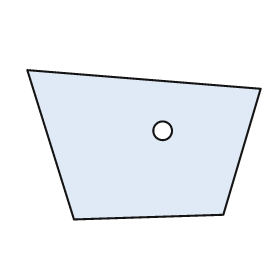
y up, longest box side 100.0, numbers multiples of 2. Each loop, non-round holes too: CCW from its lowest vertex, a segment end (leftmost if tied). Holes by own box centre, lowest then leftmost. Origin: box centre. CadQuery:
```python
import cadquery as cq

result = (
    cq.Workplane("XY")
    .moveTo(-30.0, -32.0)
    .lineTo(34.0, -30.0)
    .lineTo(50.0, 24.0)
    .lineTo(-50.0, 32.0)
    .close()
    .moveTo(8.0, 6.0)
    .circle(4.0)
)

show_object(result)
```